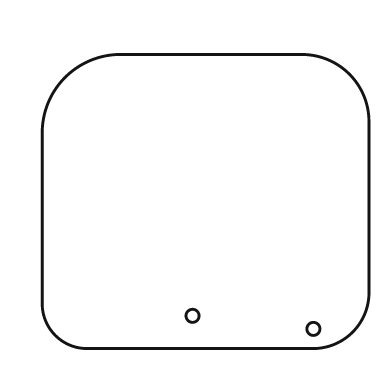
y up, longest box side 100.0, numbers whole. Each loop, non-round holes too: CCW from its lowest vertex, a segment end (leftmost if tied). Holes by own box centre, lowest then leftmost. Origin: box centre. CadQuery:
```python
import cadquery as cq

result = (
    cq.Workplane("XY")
    .moveTo(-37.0, -45.0)
    .lineTo(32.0, -45.0)
    .threePointArc((45.0, -40.0), (50.0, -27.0))
    .lineTo(50.0, 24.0)
    .threePointArc((44.0, 39.0), (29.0, 45.0))
    .lineTo(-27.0, 45.0)
    .threePointArc((-43.0, 38.0), (-50.0, 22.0))
    .lineTo(-50.0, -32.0)
    .threePointArc((-46.0, -41.0), (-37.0, -45.0))
    .close()
    .moveTo(33.0, -39.0)
    .circle(2.0)
    .moveTo(-4.0, -35.0)
    .circle(2.0)
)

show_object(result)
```